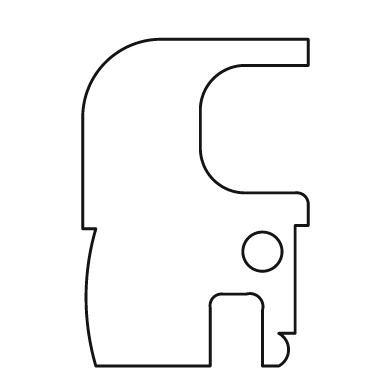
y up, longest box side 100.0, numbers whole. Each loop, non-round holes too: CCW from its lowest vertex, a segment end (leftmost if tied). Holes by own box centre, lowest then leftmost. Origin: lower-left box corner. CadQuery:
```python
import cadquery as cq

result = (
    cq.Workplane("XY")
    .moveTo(4.0, 0.0)
    .lineTo(39.0, 0.0)
    .lineTo(39.0, 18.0)
    .threePointArc((40.0, 21.0), (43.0, 22.0))
    .lineTo(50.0, 22.0)
    .threePointArc((54.0, 21.0), (55.0, 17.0))
    .lineTo(55.0, 0.0)
    .lineTo(60.0, 0.0)
    .threePointArc((63.0, 5.0), (60.0, 10.0))
    .lineTo(65.0, 10.0)
    .lineTo(65.0, 43.0)
    .lineTo(69.0, 43.0)
    .lineTo(69.0, 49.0)
    .threePointArc((68.0, 52.0), (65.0, 53.0))
    .lineTo(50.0, 53.0)
    .threePointArc((40.0, 57.0), (36.0, 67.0))
    .lineTo(36.0, 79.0)
    .threePointArc((40.0, 88.0), (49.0, 92.0))
    .lineTo(69.0, 92.0)
    .lineTo(69.0, 100.0)
    .lineTo(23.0, 100.0)
    .threePointArc((7.0, 93.0), (0.0, 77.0))
    .lineTo(0.0, 42.0)
    .lineTo(4.0, 42.0)
    .threePointArc((1.0, 21.0), (4.0, 0.0))
    .close()
    .moveTo(55.0, 35.0)
    .circle(6.0)
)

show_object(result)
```